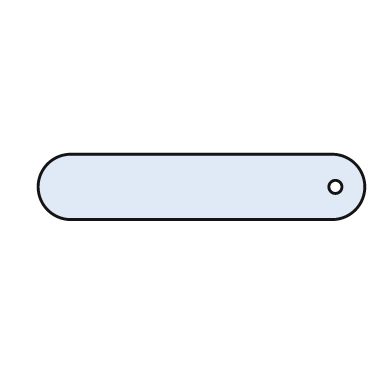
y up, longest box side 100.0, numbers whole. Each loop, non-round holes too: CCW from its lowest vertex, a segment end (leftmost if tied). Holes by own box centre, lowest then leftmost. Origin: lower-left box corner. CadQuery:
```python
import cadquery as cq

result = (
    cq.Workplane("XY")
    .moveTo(10.0, 0.0)
    .lineTo(90.0, 0.0)
    .threePointArc((100.0, 10.0), (90.0, 20.0))
    .lineTo(10.0, 20.0)
    .threePointArc((0.0, 10.0), (10.0, 0.0))
    .close()
    .moveTo(91.0, 10.0)
    .circle(2.0)
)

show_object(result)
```